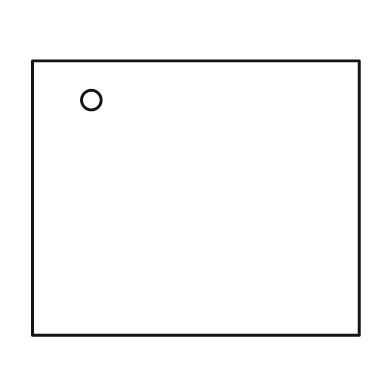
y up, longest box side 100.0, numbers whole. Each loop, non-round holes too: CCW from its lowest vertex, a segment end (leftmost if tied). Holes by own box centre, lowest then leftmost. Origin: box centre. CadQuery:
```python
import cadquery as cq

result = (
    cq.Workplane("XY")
    .moveTo(-50.0, -42.0)
    .lineTo(50.0, -42.0)
    .lineTo(50.0, 42.0)
    .lineTo(-50.0, 42.0)
    .close()
    .moveTo(-32.0, 30.0)
    .circle(3.0)
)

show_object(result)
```